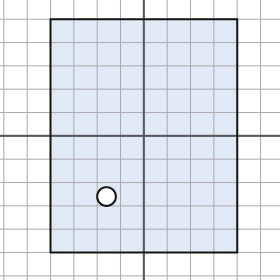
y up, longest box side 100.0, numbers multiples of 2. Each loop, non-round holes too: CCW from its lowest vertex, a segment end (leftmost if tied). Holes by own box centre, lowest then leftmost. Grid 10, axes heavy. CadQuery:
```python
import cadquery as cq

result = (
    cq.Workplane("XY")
    .moveTo(-40.0, -50.0)
    .lineTo(40.0, -50.0)
    .lineTo(40.0, 50.0)
    .lineTo(-40.0, 50.0)
    .close()
    .moveTo(-16.0, -26.0)
    .circle(4.0)
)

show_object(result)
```